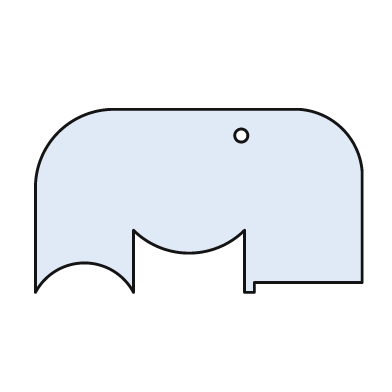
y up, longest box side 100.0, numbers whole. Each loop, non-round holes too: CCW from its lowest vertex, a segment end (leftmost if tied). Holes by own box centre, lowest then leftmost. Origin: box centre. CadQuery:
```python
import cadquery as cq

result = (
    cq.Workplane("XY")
    .moveTo(-50.0, -28.0)
    .threePointArc((-35.0, -19.0), (-20.0, -28.0))
    .lineTo(-20.0, -9.0)
    .threePointArc((-3.0, -16.0), (14.0, -9.0))
    .lineTo(14.0, -28.0)
    .lineTo(17.0, -28.0)
    .lineTo(17.0, -25.0)
    .lineTo(50.0, -25.0)
    .lineTo(50.0, 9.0)
    .threePointArc((44.0, 22.0), (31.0, 28.0))
    .lineTo(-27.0, 28.0)
    .threePointArc((-43.0, 21.0), (-50.0, 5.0))
    .close()
    .moveTo(13.0, 20.0)
    .circle(2.0)
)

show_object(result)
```